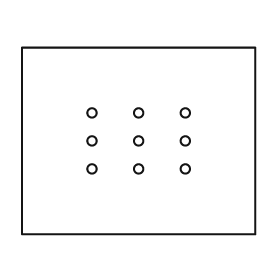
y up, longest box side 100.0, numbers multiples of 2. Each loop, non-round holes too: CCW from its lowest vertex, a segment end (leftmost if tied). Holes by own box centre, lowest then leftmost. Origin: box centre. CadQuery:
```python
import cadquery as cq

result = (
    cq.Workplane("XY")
    .moveTo(-50.0, -40.0)
    .lineTo(50.0, -40.0)
    .lineTo(50.0, 40.0)
    .lineTo(-50.0, 40.0)
    .close()
    .moveTo(-20.0, -12.0)
    .circle(2.0)
    .moveTo(0.0, -12.0)
    .circle(2.0)
    .moveTo(20.0, -12.0)
    .circle(2.0)
    .moveTo(-20.0, 0.0)
    .circle(2.0)
    .moveTo(0.0, 0.0)
    .circle(2.0)
    .moveTo(20.0, 0.0)
    .circle(2.0)
    .moveTo(-20.0, 12.0)
    .circle(2.0)
    .moveTo(0.0, 12.0)
    .circle(2.0)
    .moveTo(20.0, 12.0)
    .circle(2.0)
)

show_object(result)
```